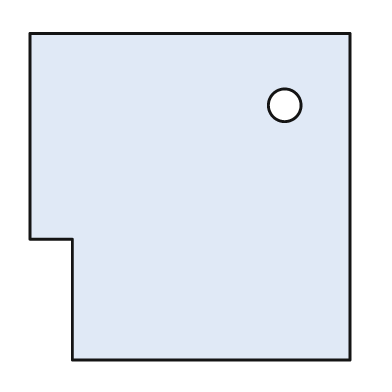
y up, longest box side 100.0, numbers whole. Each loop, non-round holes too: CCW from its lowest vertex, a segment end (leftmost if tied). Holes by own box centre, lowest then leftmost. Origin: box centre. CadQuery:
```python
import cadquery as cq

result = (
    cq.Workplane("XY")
    .moveTo(-36.0, -50.0)
    .lineTo(49.0, -50.0)
    .lineTo(49.0, 50.0)
    .lineTo(-49.0, 50.0)
    .lineTo(-49.0, -13.0)
    .lineTo(-36.0, -13.0)
    .close()
    .moveTo(29.0, 28.0)
    .circle(5.0)
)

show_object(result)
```